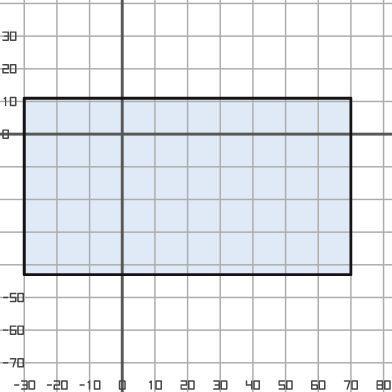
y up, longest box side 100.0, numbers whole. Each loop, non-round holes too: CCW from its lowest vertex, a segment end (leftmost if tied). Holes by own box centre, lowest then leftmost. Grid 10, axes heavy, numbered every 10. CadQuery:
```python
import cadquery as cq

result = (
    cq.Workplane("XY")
    .moveTo(-30.0, -43.0)
    .lineTo(70.0, -43.0)
    .lineTo(70.0, 11.0)
    .lineTo(-30.0, 11.0)
    .close()
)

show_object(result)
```